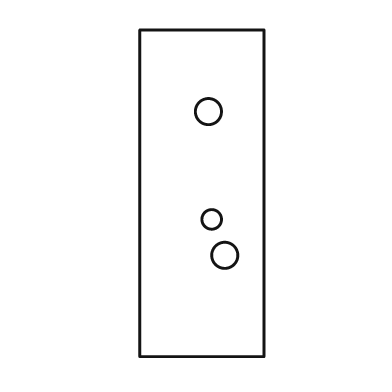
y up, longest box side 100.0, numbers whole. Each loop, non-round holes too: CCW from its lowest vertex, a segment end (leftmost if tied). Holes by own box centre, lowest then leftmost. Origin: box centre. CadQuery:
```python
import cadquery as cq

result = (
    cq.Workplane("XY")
    .moveTo(-19.0, -50.0)
    .lineTo(19.0, -50.0)
    .lineTo(19.0, 50.0)
    .lineTo(-19.0, 50.0)
    .close()
    .moveTo(7.0, -19.0)
    .circle(4.0)
    .moveTo(3.0, -8.0)
    .circle(3.0)
    .moveTo(2.0, 25.0)
    .circle(4.0)
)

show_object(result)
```